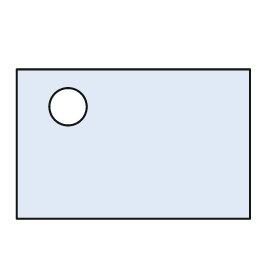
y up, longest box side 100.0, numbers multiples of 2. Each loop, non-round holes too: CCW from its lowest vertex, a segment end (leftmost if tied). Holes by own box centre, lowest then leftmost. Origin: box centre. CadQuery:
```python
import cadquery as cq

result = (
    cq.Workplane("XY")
    .moveTo(-50.0, -32.0)
    .lineTo(50.0, -32.0)
    .lineTo(50.0, 32.0)
    .lineTo(-50.0, 32.0)
    .close()
    .moveTo(-28.0, 16.0)
    .circle(8.0)
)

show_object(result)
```